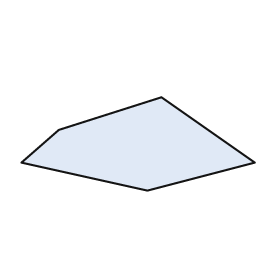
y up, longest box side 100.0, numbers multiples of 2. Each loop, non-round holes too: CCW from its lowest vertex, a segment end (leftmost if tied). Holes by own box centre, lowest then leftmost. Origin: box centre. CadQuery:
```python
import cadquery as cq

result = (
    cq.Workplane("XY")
    .moveTo(4.0, -20.0)
    .lineTo(50.0, -8.0)
    .lineTo(10.0, 20.0)
    .lineTo(-34.0, 6.0)
    .lineTo(-50.0, -8.0)
    .close()
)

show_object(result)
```